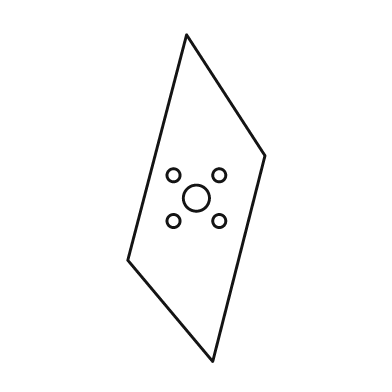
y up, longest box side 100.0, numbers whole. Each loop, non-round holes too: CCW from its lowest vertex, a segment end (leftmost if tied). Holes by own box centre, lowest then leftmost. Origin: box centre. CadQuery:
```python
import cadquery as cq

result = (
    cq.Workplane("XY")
    .moveTo(5.0, -50.0)
    .lineTo(21.0, 13.0)
    .lineTo(-3.0, 50.0)
    .lineTo(-21.0, -19.0)
    .close()
    .moveTo(-7.0, -7.0)
    .circle(2.0)
    .moveTo(7.0, -7.0)
    .circle(2.0)
    .moveTo(0.0, 0.0)
    .circle(4.0)
    .moveTo(-7.0, 7.0)
    .circle(2.0)
    .moveTo(7.0, 7.0)
    .circle(2.0)
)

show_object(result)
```